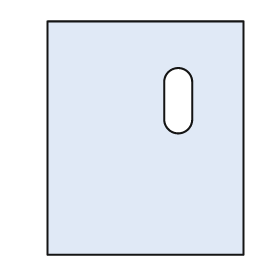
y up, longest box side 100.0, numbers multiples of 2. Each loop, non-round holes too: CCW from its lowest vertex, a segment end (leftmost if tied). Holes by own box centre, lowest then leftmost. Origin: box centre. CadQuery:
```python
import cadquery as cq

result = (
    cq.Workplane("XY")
    .moveTo(-42.0, -50.0)
    .lineTo(42.0, -50.0)
    .lineTo(42.0, 50.0)
    .lineTo(-42.0, 50.0)
    .close()
    .moveTo(8.0, 8.0)
    .threePointArc((14.0, 2.0), (20.0, 8.0))
    .lineTo(20.0, 24.0)
    .threePointArc((14.0, 30.0), (8.0, 24.0))
    .close()
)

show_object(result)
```